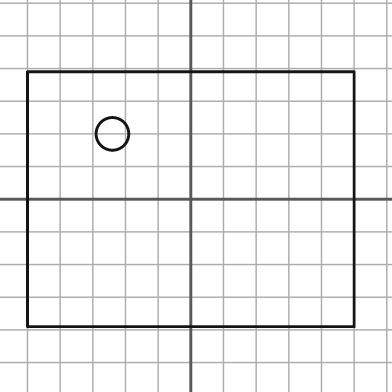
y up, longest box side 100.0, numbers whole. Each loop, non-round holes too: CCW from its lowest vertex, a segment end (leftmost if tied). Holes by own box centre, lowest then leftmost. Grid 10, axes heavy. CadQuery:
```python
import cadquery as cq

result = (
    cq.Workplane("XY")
    .moveTo(-50.0, -39.0)
    .lineTo(50.0, -39.0)
    .lineTo(50.0, 39.0)
    .lineTo(-50.0, 39.0)
    .close()
    .moveTo(-24.0, 20.0)
    .circle(5.0)
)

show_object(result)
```